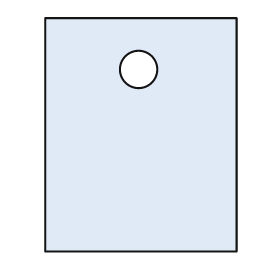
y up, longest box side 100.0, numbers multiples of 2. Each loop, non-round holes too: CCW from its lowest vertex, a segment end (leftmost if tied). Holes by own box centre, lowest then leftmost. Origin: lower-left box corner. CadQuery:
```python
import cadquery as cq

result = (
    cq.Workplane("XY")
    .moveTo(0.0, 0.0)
    .lineTo(82.0, 0.0)
    .lineTo(82.0, 100.0)
    .lineTo(0.0, 100.0)
    .close()
    .moveTo(40.0, 78.0)
    .circle(8.0)
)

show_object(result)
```